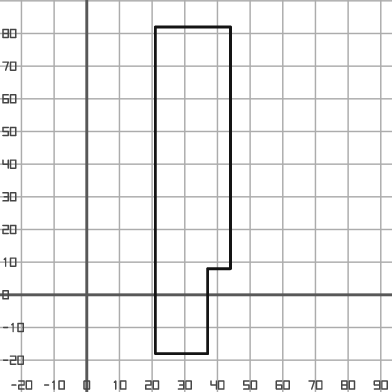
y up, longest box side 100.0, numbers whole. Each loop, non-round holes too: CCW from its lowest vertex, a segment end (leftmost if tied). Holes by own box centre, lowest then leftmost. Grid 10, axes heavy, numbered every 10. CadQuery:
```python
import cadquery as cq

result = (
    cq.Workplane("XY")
    .moveTo(21.0, -18.0)
    .lineTo(37.0, -18.0)
    .lineTo(37.0, 8.0)
    .lineTo(44.0, 8.0)
    .lineTo(44.0, 82.0)
    .lineTo(21.0, 82.0)
    .close()
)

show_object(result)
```